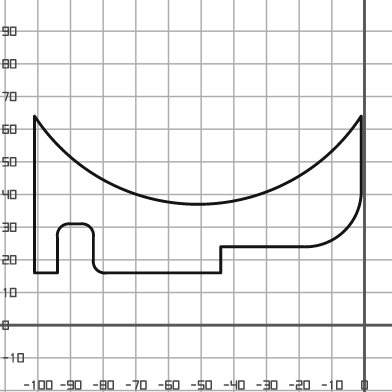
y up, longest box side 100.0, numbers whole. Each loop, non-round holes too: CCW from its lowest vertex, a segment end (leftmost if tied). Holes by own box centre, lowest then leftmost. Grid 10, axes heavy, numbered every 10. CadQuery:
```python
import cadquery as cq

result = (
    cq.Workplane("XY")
    .moveTo(-101.0, 16.0)
    .lineTo(-94.0, 16.0)
    .lineTo(-94.0, 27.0)
    .threePointArc((-93.0, 30.0), (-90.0, 31.0))
    .lineTo(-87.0, 31.0)
    .threePointArc((-84.0, 30.0), (-83.0, 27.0))
    .lineTo(-83.0, 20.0)
    .threePointArc((-82.0, 17.0), (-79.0, 16.0))
    .lineTo(-44.0, 16.0)
    .lineTo(-44.0, 24.0)
    .lineTo(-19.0, 24.0)
    .threePointArc((-6.0, 29.0), (-1.0, 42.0))
    .lineTo(-1.0, 64.0)
    .threePointArc((-51.0, 37.0), (-101.0, 64.0))
    .close()
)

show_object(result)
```